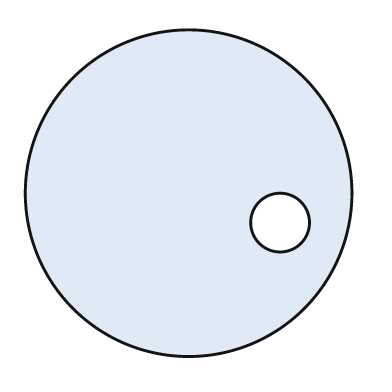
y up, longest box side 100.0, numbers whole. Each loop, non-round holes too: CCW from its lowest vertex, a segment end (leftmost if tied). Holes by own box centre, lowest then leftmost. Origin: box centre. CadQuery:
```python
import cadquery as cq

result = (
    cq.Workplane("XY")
    .moveTo(0.0, 0.0)
    .circle(50.0)
    .moveTo(28.0, -9.0)
    .circle(9.0)
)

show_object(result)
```